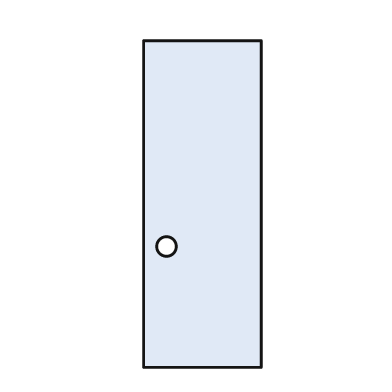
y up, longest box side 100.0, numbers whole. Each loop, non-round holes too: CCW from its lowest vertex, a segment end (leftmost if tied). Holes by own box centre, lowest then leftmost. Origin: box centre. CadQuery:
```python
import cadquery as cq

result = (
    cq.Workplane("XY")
    .moveTo(-18.0, -50.0)
    .lineTo(18.0, -50.0)
    .lineTo(18.0, 50.0)
    .lineTo(-18.0, 50.0)
    .close()
    .moveTo(-11.0, -13.0)
    .circle(3.0)
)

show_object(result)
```